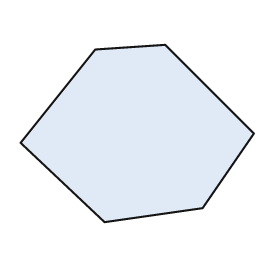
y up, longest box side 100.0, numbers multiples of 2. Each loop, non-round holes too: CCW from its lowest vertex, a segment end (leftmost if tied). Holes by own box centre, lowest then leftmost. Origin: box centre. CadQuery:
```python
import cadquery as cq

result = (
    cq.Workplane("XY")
    .moveTo(-14.0, -38.0)
    .lineTo(28.0, -32.0)
    .lineTo(50.0, 0.0)
    .lineTo(12.0, 38.0)
    .lineTo(-18.0, 36.0)
    .lineTo(-50.0, -4.0)
    .close()
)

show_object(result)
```